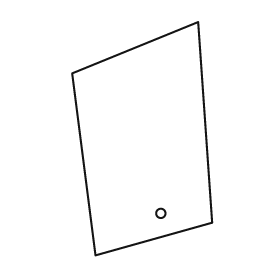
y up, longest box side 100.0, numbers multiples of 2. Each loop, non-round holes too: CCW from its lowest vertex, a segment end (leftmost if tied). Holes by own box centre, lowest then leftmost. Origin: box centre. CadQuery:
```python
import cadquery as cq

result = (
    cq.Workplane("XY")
    .moveTo(-20.0, -50.0)
    .lineTo(30.0, -36.0)
    .lineTo(24.0, 50.0)
    .lineTo(-30.0, 28.0)
    .close()
    .moveTo(8.0, -32.0)
    .circle(2.0)
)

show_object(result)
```